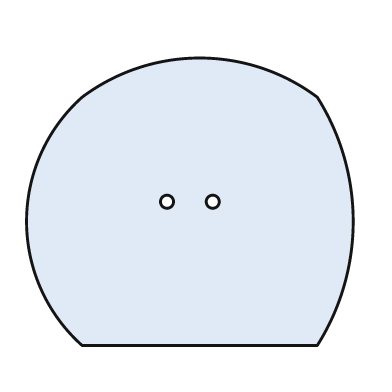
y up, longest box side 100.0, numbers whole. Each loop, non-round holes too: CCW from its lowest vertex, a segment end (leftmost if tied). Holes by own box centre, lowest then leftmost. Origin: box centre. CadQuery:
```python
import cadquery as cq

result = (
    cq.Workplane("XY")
    .moveTo(-33.0, -44.0)
    .lineTo(39.0, -44.0)
    .threePointArc((50.0, -6.0), (39.0, 32.0))
    .threePointArc((3.0, 44.0), (-33.0, 32.0))
    .threePointArc((-50.0, -6.0), (-33.0, -44.0))
    .close()
    .moveTo(-7.0, 0.0)
    .circle(2.0)
    .moveTo(7.0, 0.0)
    .circle(2.0)
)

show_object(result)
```